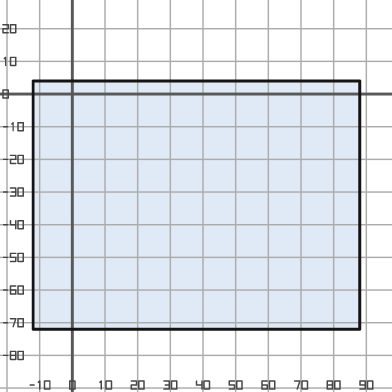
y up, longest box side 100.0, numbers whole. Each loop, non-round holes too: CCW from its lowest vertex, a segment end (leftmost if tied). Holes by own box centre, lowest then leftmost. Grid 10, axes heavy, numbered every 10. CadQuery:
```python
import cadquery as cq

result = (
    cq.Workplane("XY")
    .moveTo(-12.0, -72.0)
    .lineTo(88.0, -72.0)
    .lineTo(88.0, 4.0)
    .lineTo(-12.0, 4.0)
    .close()
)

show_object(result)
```